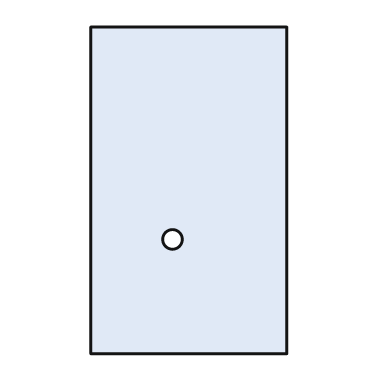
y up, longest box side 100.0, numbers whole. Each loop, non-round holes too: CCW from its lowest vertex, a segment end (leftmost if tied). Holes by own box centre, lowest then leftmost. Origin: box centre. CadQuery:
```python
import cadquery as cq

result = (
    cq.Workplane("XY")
    .moveTo(-30.0, -50.0)
    .lineTo(30.0, -50.0)
    .lineTo(30.0, 50.0)
    .lineTo(-30.0, 50.0)
    .close()
    .moveTo(-5.0, -15.0)
    .circle(3.0)
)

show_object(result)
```